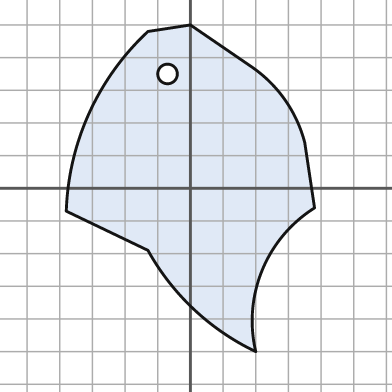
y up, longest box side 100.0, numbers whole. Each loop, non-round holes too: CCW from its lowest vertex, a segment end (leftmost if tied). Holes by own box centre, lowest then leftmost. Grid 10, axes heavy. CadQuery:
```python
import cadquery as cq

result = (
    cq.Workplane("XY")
    .moveTo(20.0, -50.0)
    .threePointArc((22.0, -25.0), (38.0, -6.0))
    .lineTo(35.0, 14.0)
    .threePointArc((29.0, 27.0), (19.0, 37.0))
    .lineTo(0.0, 50.0)
    .lineTo(-13.0, 48.0)
    .threePointArc((-31.0, 23.0), (-38.0, -7.0))
    .lineTo(-13.0, -19.0)
    .threePointArc((1.0, -37.0), (20.0, -50.0))
    .close()
    .moveTo(-7.0, 35.0)
    .circle(3.0)
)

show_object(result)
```